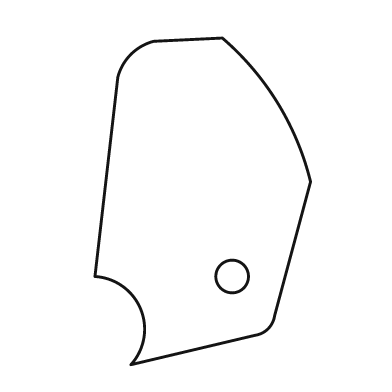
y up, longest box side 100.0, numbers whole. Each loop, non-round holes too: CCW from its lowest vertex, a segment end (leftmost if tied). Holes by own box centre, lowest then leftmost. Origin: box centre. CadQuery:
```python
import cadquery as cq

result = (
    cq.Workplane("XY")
    .moveTo(-22.0, -50.0)
    .lineTo(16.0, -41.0)
    .threePointArc((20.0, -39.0), (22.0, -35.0))
    .lineTo(33.0, 6.0)
    .threePointArc((23.0, 30.0), (6.0, 50.0))
    .lineTo(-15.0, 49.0)
    .threePointArc((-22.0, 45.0), (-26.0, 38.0))
    .lineTo(-33.0, -23.0)
    .threePointArc((-19.0, -33.0), (-22.0, -50.0))
    .close()
    .moveTo(9.0, -23.0)
    .circle(5.0)
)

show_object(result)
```